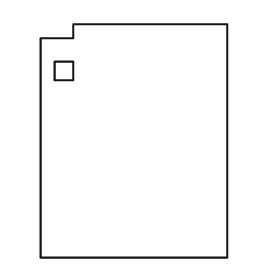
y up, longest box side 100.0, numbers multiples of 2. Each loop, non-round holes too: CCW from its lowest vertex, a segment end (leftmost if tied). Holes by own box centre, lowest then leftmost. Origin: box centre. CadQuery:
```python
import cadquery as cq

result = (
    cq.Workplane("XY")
    .moveTo(-40.0, -50.0)
    .lineTo(40.0, -50.0)
    .lineTo(40.0, 50.0)
    .lineTo(-26.0, 50.0)
    .lineTo(-26.0, 44.0)
    .lineTo(-40.0, 44.0)
    .close()
    .moveTo(-34.0, 26.0)
    .lineTo(-26.0, 26.0)
    .lineTo(-26.0, 34.0)
    .lineTo(-34.0, 34.0)
    .close()
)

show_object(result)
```